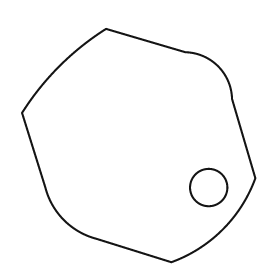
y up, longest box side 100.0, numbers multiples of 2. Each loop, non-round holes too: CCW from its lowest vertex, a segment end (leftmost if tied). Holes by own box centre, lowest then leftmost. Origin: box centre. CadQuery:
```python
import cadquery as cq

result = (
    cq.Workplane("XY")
    .moveTo(14.0, -50.0)
    .threePointArc((36.0, -36.0), (50.0, -14.0))
    .lineTo(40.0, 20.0)
    .threePointArc((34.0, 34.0), (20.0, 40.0))
    .lineTo(-14.0, 50.0)
    .threePointArc((-34.0, 34.0), (-50.0, 14.0))
    .lineTo(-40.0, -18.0)
    .threePointArc((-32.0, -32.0), (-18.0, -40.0))
    .close()
    .moveTo(30.0, -18.0)
    .circle(8.0)
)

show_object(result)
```